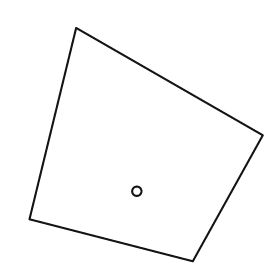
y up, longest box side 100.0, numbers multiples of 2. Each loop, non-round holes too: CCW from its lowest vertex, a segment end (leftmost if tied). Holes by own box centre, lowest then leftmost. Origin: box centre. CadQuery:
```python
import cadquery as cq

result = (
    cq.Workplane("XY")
    .moveTo(20.0, -50.0)
    .lineTo(50.0, 4.0)
    .lineTo(-30.0, 50.0)
    .lineTo(-50.0, -32.0)
    .close()
    .moveTo(-4.0, -20.0)
    .circle(2.0)
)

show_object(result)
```